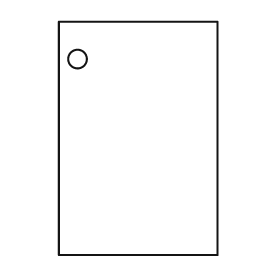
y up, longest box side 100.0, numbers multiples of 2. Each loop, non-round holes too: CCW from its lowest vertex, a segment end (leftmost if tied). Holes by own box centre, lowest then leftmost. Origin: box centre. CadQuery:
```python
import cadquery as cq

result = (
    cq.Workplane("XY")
    .moveTo(-34.0, -50.0)
    .lineTo(34.0, -50.0)
    .lineTo(34.0, 50.0)
    .lineTo(-34.0, 50.0)
    .close()
    .moveTo(-26.0, 34.0)
    .circle(4.0)
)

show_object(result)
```